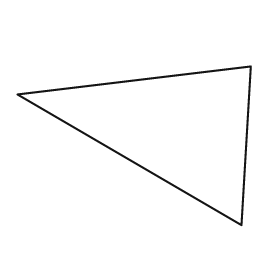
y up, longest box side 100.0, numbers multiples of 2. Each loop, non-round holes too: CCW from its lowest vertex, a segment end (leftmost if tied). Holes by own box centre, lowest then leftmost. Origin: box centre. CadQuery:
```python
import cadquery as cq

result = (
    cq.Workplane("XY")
    .moveTo(46.0, -34.0)
    .lineTo(50.0, 34.0)
    .lineTo(-50.0, 22.0)
    .close()
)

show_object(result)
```